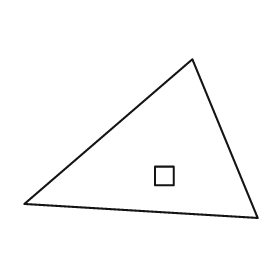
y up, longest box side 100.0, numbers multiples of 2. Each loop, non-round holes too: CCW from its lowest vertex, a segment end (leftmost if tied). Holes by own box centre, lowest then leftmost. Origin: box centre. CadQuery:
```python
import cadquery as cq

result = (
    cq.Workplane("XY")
    .moveTo(50.0, -34.0)
    .lineTo(22.0, 34.0)
    .lineTo(-50.0, -28.0)
    .close()
    .moveTo(6.0, -20.0)
    .lineTo(14.0, -20.0)
    .lineTo(14.0, -12.0)
    .lineTo(6.0, -12.0)
    .close()
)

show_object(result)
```